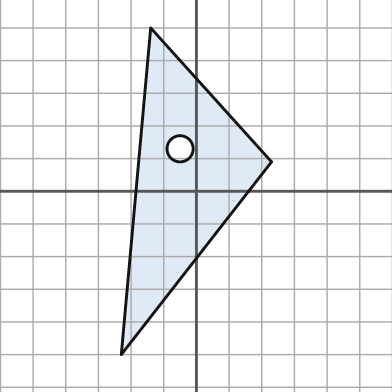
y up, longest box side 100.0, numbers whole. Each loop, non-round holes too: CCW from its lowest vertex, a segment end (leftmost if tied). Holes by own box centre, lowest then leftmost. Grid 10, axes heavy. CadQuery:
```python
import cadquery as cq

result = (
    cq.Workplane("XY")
    .moveTo(-23.0, -50.0)
    .lineTo(23.0, 9.0)
    .lineTo(-14.0, 50.0)
    .close()
    .moveTo(-5.0, 13.0)
    .circle(4.0)
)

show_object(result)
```